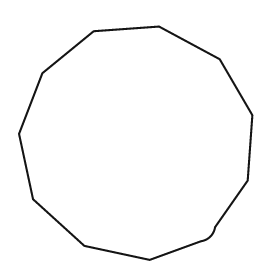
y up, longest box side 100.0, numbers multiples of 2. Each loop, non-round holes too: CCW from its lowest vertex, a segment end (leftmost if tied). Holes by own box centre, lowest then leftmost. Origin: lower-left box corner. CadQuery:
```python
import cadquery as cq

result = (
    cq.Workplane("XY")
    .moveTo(56.0, 0.0)
    .lineTo(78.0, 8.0)
    .threePointArc((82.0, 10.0), (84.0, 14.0))
    .lineTo(98.0, 34.0)
    .lineTo(100.0, 62.0)
    .lineTo(86.0, 86.0)
    .lineTo(60.0, 100.0)
    .lineTo(32.0, 98.0)
    .lineTo(10.0, 80.0)
    .lineTo(0.0, 54.0)
    .lineTo(6.0, 26.0)
    .lineTo(28.0, 6.0)
    .close()
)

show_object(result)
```